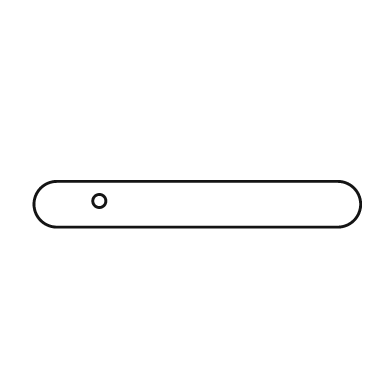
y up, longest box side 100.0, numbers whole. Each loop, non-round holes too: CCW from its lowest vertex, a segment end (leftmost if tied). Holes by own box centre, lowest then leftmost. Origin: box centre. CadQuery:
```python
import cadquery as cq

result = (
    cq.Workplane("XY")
    .moveTo(-43.0, -7.0)
    .lineTo(43.0, -7.0)
    .threePointArc((50.0, 0.0), (43.0, 7.0))
    .lineTo(-43.0, 7.0)
    .threePointArc((-50.0, 0.0), (-43.0, -7.0))
    .close()
    .moveTo(-30.0, 1.0)
    .circle(2.0)
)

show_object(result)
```